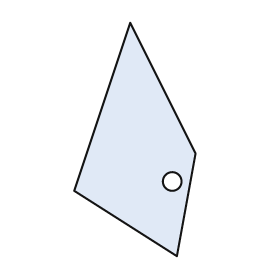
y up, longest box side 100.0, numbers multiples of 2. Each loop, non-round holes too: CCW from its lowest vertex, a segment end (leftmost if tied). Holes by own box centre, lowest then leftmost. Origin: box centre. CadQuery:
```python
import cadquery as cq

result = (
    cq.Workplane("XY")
    .moveTo(18.0, -50.0)
    .lineTo(26.0, -6.0)
    .lineTo(-2.0, 50.0)
    .lineTo(-26.0, -22.0)
    .close()
    .moveTo(16.0, -18.0)
    .circle(4.0)
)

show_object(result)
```